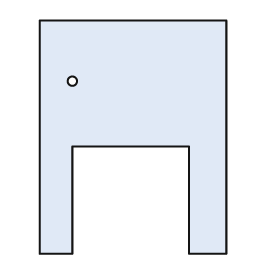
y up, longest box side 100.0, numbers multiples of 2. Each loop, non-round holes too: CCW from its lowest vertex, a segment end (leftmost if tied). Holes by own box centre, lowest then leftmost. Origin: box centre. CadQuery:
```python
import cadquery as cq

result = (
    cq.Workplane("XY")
    .moveTo(-40.0, -50.0)
    .lineTo(-26.0, -50.0)
    .lineTo(-26.0, -4.0)
    .lineTo(24.0, -4.0)
    .lineTo(24.0, -50.0)
    .lineTo(40.0, -50.0)
    .lineTo(40.0, 50.0)
    .lineTo(-40.0, 50.0)
    .close()
    .moveTo(-26.0, 24.0)
    .circle(2.0)
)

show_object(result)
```